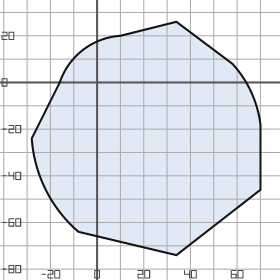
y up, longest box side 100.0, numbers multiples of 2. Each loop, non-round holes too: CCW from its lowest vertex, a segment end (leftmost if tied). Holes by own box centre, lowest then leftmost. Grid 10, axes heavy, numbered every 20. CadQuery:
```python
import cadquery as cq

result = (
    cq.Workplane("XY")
    .moveTo(34.0, -74.0)
    .lineTo(70.0, -46.0)
    .lineTo(70.0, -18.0)
    .threePointArc((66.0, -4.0), (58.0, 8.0))
    .lineTo(34.0, 26.0)
    .lineTo(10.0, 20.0)
    .threePointArc((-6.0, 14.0), (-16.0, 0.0))
    .lineTo(-28.0, -24.0)
    .threePointArc((-22.0, -46.0), (-8.0, -64.0))
    .close()
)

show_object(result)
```